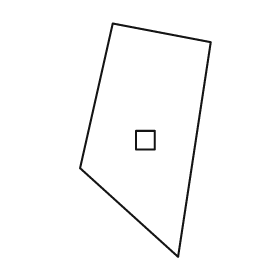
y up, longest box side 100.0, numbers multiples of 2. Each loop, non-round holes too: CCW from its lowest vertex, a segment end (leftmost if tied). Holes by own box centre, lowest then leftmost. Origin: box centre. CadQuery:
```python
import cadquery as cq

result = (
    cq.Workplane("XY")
    .moveTo(14.0, -50.0)
    .lineTo(28.0, 42.0)
    .lineTo(-14.0, 50.0)
    .lineTo(-28.0, -12.0)
    .close()
    .moveTo(-4.0, -4.0)
    .lineTo(4.0, -4.0)
    .lineTo(4.0, 4.0)
    .lineTo(-4.0, 4.0)
    .close()
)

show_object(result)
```